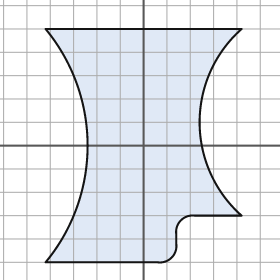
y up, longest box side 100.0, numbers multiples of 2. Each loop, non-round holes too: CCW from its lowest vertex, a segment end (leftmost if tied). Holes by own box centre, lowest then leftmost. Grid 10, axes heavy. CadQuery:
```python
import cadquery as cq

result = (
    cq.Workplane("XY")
    .moveTo(-42.0, -50.0)
    .lineTo(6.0, -50.0)
    .threePointArc((12.0, -48.0), (14.0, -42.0))
    .lineTo(14.0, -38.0)
    .threePointArc((16.0, -32.0), (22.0, -30.0))
    .lineTo(42.0, -30.0)
    .threePointArc((24.0, 10.0), (42.0, 50.0))
    .lineTo(-42.0, 50.0)
    .threePointArc((-24.0, 0.0), (-42.0, -50.0))
    .close()
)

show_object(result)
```